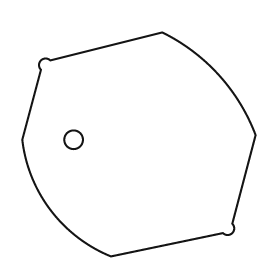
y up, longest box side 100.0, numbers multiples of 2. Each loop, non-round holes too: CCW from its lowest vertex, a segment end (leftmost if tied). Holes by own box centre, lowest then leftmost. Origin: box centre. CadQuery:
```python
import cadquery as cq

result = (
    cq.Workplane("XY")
    .moveTo(-12.0, -48.0)
    .lineTo(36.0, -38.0)
    .threePointArc((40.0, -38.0), (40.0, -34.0))
    .lineTo(50.0, 4.0)
    .threePointArc((34.0, 30.0), (10.0, 48.0))
    .lineTo(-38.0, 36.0)
    .threePointArc((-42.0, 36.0), (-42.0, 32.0))
    .lineTo(-50.0, 2.0)
    .threePointArc((-38.0, -28.0), (-12.0, -48.0))
    .close()
    .moveTo(-28.0, 2.0)
    .circle(4.0)
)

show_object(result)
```